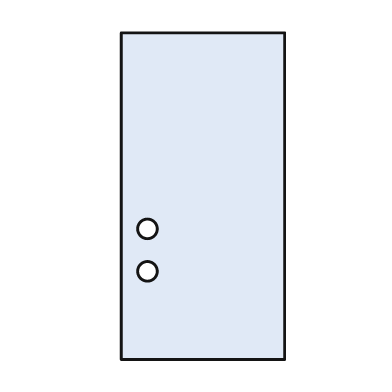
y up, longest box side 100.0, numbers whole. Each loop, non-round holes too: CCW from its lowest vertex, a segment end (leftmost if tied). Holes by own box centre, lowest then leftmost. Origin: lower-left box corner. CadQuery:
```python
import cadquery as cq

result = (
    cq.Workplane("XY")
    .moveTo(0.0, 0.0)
    .lineTo(50.0, 0.0)
    .lineTo(50.0, 100.0)
    .lineTo(0.0, 100.0)
    .close()
    .moveTo(8.0, 27.0)
    .circle(3.0)
    .moveTo(8.0, 40.0)
    .circle(3.0)
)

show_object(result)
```